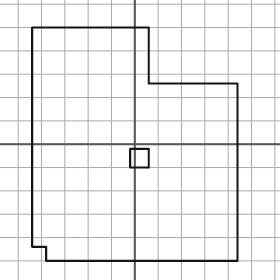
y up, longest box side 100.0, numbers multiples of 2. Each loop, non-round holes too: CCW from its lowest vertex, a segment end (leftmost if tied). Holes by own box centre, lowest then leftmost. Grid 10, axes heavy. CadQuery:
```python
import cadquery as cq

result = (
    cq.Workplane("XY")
    .moveTo(-38.0, -50.0)
    .lineTo(44.0, -50.0)
    .lineTo(44.0, 26.0)
    .lineTo(6.0, 26.0)
    .lineTo(6.0, 50.0)
    .lineTo(-44.0, 50.0)
    .lineTo(-44.0, -44.0)
    .lineTo(-38.0, -44.0)
    .close()
    .moveTo(-2.0, -10.0)
    .lineTo(6.0, -10.0)
    .lineTo(6.0, -2.0)
    .lineTo(-2.0, -2.0)
    .close()
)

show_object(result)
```